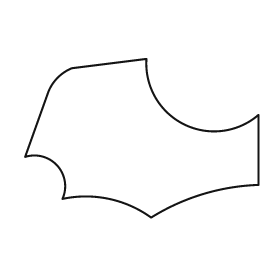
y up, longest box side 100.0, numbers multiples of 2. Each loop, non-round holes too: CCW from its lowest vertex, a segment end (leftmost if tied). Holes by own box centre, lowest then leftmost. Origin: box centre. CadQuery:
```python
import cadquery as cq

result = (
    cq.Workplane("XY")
    .moveTo(4.0, -34.0)
    .threePointArc((26.0, -24.0), (50.0, -20.0))
    .lineTo(50.0, 10.0)
    .threePointArc((18.0, 6.0), (2.0, 34.0))
    .lineTo(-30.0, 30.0)
    .threePointArc((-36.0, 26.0), (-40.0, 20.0))
    .lineTo(-50.0, -8.0)
    .threePointArc((-36.0, -12.0), (-34.0, -26.0))
    .threePointArc((-14.0, -26.0), (4.0, -34.0))
    .close()
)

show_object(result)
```